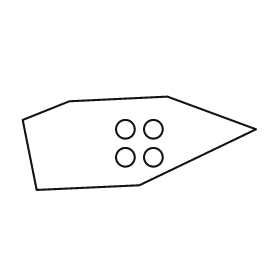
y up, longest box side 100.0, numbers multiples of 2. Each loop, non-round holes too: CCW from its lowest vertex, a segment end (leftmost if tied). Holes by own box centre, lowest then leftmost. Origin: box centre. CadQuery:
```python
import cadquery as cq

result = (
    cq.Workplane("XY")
    .moveTo(-44.0, -20.0)
    .lineTo(0.0, -18.0)
    .lineTo(50.0, 6.0)
    .lineTo(12.0, 20.0)
    .lineTo(-30.0, 18.0)
    .lineTo(-50.0, 10.0)
    .close()
    .moveTo(-6.0, -6.0)
    .circle(4.0)
    .moveTo(6.0, -6.0)
    .circle(4.0)
    .moveTo(-6.0, 6.0)
    .circle(4.0)
    .moveTo(6.0, 6.0)
    .circle(4.0)
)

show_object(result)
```